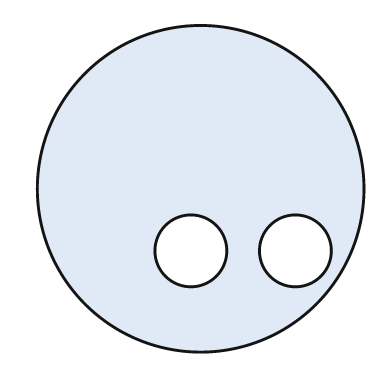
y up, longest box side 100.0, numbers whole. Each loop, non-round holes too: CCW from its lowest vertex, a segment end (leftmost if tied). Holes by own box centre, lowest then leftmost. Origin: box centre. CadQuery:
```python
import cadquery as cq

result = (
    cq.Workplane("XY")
    .moveTo(0.0, 0.0)
    .circle(50.0)
    .moveTo(-3.0, -19.0)
    .circle(11.0)
    .moveTo(29.0, -19.0)
    .circle(11.0)
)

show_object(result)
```